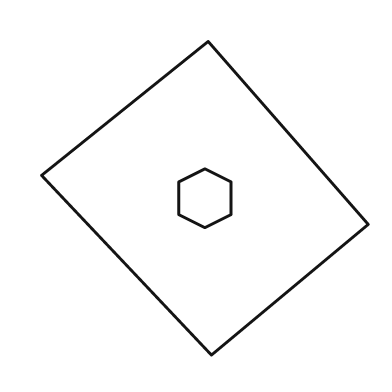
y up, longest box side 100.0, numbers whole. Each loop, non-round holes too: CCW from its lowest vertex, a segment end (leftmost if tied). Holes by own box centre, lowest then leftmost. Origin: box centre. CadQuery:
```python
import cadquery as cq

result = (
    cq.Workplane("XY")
    .moveTo(2.0, -48.0)
    .lineTo(50.0, -8.0)
    .lineTo(1.0, 48.0)
    .lineTo(-50.0, 7.0)
    .close()
    .moveTo(0.0, -9.0)
    .lineTo(8.0, -5.0)
    .lineTo(8.0, 5.0)
    .lineTo(0.0, 9.0)
    .lineTo(-8.0, 5.0)
    .lineTo(-8.0, -5.0)
    .close()
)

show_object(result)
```